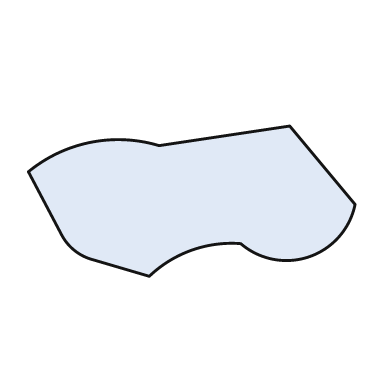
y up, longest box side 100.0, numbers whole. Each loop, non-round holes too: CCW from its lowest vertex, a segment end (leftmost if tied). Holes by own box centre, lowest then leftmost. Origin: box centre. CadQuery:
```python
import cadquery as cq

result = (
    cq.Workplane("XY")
    .moveTo(-13.0, -23.0)
    .threePointArc((0.0, -15.0), (15.0, -13.0))
    .threePointArc((36.0, -17.0), (50.0, -1.0))
    .lineTo(30.0, 23.0)
    .lineTo(-10.0, 17.0)
    .threePointArc((-31.0, 18.0), (-50.0, 9.0))
    .lineTo(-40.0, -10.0)
    .threePointArc((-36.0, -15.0), (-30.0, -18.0))
    .close()
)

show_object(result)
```